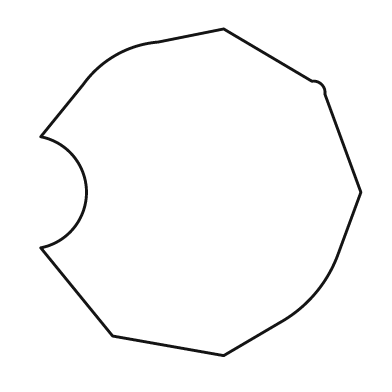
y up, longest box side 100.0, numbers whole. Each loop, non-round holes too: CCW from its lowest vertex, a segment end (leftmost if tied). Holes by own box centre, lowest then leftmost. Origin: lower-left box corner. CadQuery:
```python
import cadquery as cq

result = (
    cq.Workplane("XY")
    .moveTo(56.0, 0.0)
    .lineTo(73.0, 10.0)
    .threePointArc((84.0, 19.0), (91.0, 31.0))
    .lineTo(98.0, 50.0)
    .lineTo(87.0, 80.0)
    .threePointArc((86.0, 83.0), (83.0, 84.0))
    .lineTo(56.0, 100.0)
    .lineTo(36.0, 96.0)
    .threePointArc((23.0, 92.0), (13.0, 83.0))
    .lineTo(0.0, 67.0)
    .threePointArc((14.0, 50.0), (0.0, 33.0))
    .lineTo(22.0, 6.0)
    .close()
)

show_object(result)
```